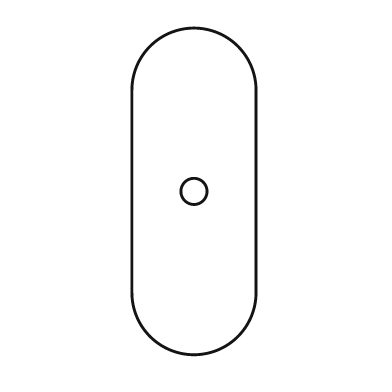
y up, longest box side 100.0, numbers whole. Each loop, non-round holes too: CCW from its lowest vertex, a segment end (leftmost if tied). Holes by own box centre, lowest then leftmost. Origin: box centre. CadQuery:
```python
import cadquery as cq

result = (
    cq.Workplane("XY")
    .moveTo(-19.0, -31.0)
    .threePointArc((0.0, -50.0), (19.0, -31.0))
    .lineTo(19.0, 31.0)
    .threePointArc((0.0, 50.0), (-19.0, 31.0))
    .close()
    .moveTo(0.0, 0.0)
    .circle(4.0)
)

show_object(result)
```